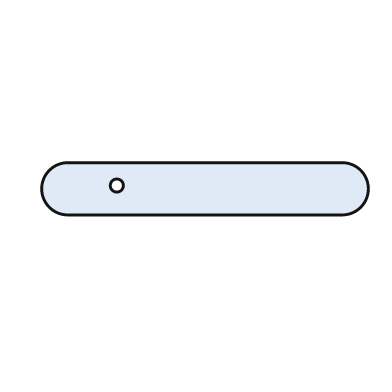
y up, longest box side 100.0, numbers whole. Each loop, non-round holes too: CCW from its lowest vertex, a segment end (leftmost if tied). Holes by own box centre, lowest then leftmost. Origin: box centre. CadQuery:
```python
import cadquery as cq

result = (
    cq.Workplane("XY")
    .moveTo(-42.0, -8.0)
    .lineTo(42.0, -8.0)
    .threePointArc((50.0, 0.0), (42.0, 8.0))
    .lineTo(-42.0, 8.0)
    .threePointArc((-50.0, 0.0), (-42.0, -8.0))
    .close()
    .moveTo(-27.0, 1.0)
    .circle(2.0)
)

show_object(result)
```